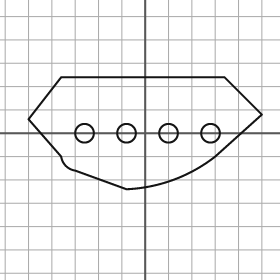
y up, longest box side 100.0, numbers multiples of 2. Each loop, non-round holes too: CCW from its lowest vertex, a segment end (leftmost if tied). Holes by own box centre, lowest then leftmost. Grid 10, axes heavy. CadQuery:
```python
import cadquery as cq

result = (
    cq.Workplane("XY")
    .moveTo(-8.0, -24.0)
    .threePointArc((12.0, -20.0), (30.0, -10.0))
    .lineTo(50.0, 8.0)
    .lineTo(34.0, 24.0)
    .lineTo(-36.0, 24.0)
    .lineTo(-50.0, 6.0)
    .lineTo(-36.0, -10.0)
    .threePointArc((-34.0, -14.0), (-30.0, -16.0))
    .close()
    .moveTo(-26.0, 0.0)
    .circle(4.0)
    .moveTo(-8.0, 0.0)
    .circle(4.0)
    .moveTo(10.0, 0.0)
    .circle(4.0)
    .moveTo(28.0, 0.0)
    .circle(4.0)
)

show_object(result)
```